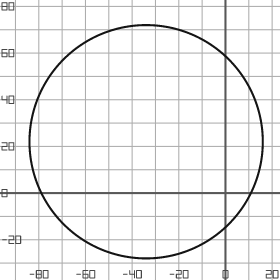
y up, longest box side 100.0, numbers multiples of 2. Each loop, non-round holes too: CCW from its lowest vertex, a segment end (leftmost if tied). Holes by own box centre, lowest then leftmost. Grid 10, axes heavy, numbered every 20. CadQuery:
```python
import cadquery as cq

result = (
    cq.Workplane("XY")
    .moveTo(-34.0, 22.0)
    .circle(50.0)
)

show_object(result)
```